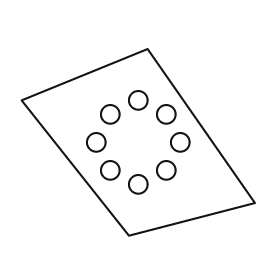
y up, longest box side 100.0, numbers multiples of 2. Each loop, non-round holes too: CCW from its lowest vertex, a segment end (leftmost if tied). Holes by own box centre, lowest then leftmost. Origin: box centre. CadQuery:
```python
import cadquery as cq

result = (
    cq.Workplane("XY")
    .moveTo(-4.0, -40.0)
    .lineTo(50.0, -26.0)
    .lineTo(4.0, 40.0)
    .lineTo(-50.0, 18.0)
    .close()
    .moveTo(0.0, -18.0)
    .circle(4.0)
    .moveTo(-12.0, -12.0)
    .circle(4.0)
    .moveTo(12.0, -12.0)
    .circle(4.0)
    .moveTo(-18.0, 0.0)
    .circle(4.0)
    .moveTo(18.0, 0.0)
    .circle(4.0)
    .moveTo(-12.0, 12.0)
    .circle(4.0)
    .moveTo(12.0, 12.0)
    .circle(4.0)
    .moveTo(0.0, 18.0)
    .circle(4.0)
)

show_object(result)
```